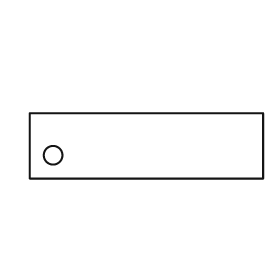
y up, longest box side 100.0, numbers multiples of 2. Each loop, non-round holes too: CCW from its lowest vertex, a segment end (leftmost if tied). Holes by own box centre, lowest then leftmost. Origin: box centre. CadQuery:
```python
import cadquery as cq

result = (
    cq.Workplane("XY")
    .moveTo(-50.0, -14.0)
    .lineTo(50.0, -14.0)
    .lineTo(50.0, 14.0)
    .lineTo(-50.0, 14.0)
    .close()
    .moveTo(-40.0, -4.0)
    .circle(4.0)
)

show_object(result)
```